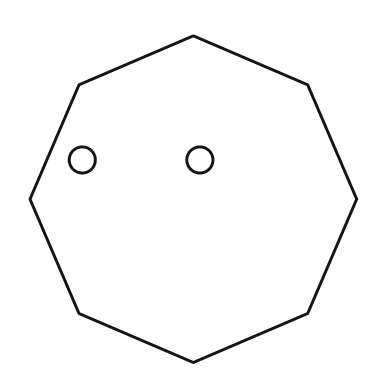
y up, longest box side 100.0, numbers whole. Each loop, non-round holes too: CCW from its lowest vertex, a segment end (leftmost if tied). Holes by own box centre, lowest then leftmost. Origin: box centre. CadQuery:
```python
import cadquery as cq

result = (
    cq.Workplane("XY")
    .moveTo(0.0, -50.0)
    .lineTo(35.0, -35.0)
    .lineTo(50.0, 0.0)
    .lineTo(35.0, 35.0)
    .lineTo(0.0, 50.0)
    .lineTo(-35.0, 35.0)
    .lineTo(-50.0, 0.0)
    .lineTo(-35.0, -35.0)
    .close()
    .moveTo(-34.0, 12.0)
    .circle(4.0)
    .moveTo(2.0, 12.0)
    .circle(4.0)
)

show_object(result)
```